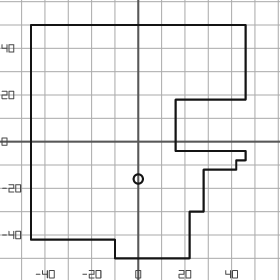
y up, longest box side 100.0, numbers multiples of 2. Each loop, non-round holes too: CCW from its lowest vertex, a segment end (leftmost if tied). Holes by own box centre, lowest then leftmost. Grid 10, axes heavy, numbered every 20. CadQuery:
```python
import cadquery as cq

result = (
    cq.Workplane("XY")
    .moveTo(-10.0, -50.0)
    .lineTo(22.0, -50.0)
    .lineTo(22.0, -30.0)
    .lineTo(28.0, -30.0)
    .lineTo(28.0, -12.0)
    .lineTo(42.0, -12.0)
    .lineTo(42.0, -8.0)
    .lineTo(46.0, -8.0)
    .lineTo(46.0, -4.0)
    .lineTo(16.0, -4.0)
    .lineTo(16.0, 18.0)
    .lineTo(46.0, 18.0)
    .lineTo(46.0, 50.0)
    .lineTo(-46.0, 50.0)
    .lineTo(-46.0, -42.0)
    .lineTo(-10.0, -42.0)
    .close()
    .moveTo(0.0, -16.0)
    .circle(2.0)
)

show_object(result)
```